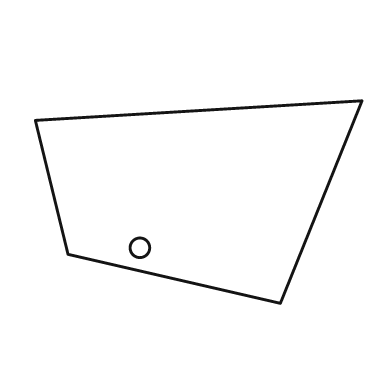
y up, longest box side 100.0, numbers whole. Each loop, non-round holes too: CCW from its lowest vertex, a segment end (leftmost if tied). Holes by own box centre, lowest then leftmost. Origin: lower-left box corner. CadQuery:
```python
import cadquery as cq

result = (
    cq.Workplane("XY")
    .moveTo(75.0, 0.0)
    .lineTo(100.0, 62.0)
    .lineTo(0.0, 56.0)
    .lineTo(10.0, 15.0)
    .close()
    .moveTo(32.0, 17.0)
    .circle(3.0)
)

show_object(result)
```